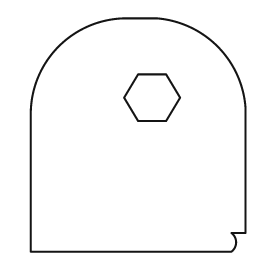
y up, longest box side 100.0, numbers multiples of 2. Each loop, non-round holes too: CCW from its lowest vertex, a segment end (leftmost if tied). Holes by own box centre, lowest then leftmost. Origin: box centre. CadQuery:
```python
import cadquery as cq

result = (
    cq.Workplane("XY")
    .moveTo(-46.0, -50.0)
    .lineTo(40.0, -50.0)
    .threePointArc((42.0, -46.0), (40.0, -42.0))
    .lineTo(46.0, -42.0)
    .lineTo(46.0, 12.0)
    .threePointArc((34.0, 38.0), (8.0, 50.0))
    .lineTo(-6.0, 50.0)
    .threePointArc((-34.0, 38.0), (-46.0, 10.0))
    .close()
    .moveTo(0.0, 6.0)
    .lineTo(12.0, 6.0)
    .lineTo(18.0, 16.0)
    .lineTo(12.0, 26.0)
    .lineTo(0.0, 26.0)
    .lineTo(-6.0, 16.0)
    .close()
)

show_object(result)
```